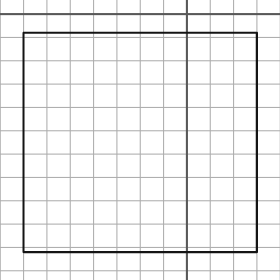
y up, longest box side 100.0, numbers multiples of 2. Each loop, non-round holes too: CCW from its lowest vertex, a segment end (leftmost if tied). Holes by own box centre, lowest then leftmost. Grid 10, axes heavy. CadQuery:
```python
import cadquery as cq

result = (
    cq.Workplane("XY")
    .moveTo(-70.0, -102.0)
    .lineTo(30.0, -102.0)
    .lineTo(30.0, -8.0)
    .lineTo(-70.0, -8.0)
    .close()
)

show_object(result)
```